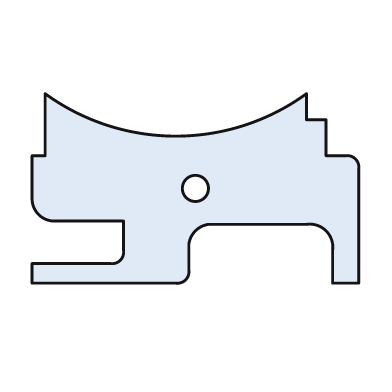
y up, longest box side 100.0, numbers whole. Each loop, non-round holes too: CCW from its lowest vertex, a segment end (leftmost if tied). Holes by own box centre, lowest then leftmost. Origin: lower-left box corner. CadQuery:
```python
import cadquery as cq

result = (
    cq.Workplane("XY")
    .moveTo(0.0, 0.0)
    .lineTo(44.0, 0.0)
    .threePointArc((47.0, 1.0), (48.0, 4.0))
    .lineTo(48.0, 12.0)
    .threePointArc((50.0, 16.0), (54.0, 18.0))
    .lineTo(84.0, 18.0)
    .threePointArc((90.0, 16.0), (92.0, 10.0))
    .lineTo(92.0, 0.0)
    .lineTo(100.0, 0.0)
    .lineTo(100.0, 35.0)
    .threePointArc((99.0, 38.0), (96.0, 39.0))
    .lineTo(90.0, 39.0)
    .lineTo(90.0, 50.0)
    .lineTo(84.0, 50.0)
    .lineTo(84.0, 58.0)
    .threePointArc((44.0, 45.0), (4.0, 58.0))
    .lineTo(4.0, 39.0)
    .lineTo(0.0, 39.0)
    .lineTo(0.0, 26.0)
    .threePointArc((2.0, 21.0), (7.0, 19.0))
    .lineTo(28.0, 19.0)
    .lineTo(28.0, 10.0)
    .threePointArc((27.0, 7.0), (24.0, 6.0))
    .lineTo(0.0, 6.0)
    .close()
    .moveTo(50.0, 29.0)
    .circle(4.0)
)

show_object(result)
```